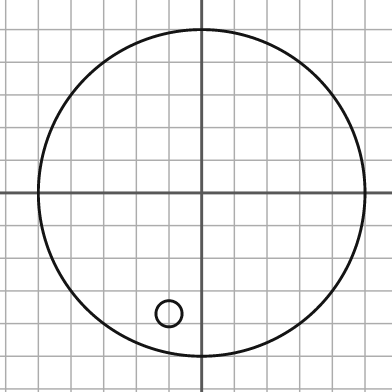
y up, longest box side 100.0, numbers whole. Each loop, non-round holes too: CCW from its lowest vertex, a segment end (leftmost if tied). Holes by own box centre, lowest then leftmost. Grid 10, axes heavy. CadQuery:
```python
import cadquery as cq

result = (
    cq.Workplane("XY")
    .moveTo(0.0, 0.0)
    .circle(50.0)
    .moveTo(-10.0, -37.0)
    .circle(4.0)
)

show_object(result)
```